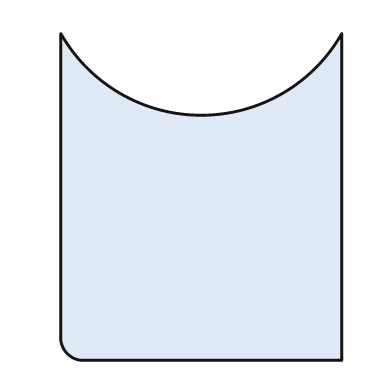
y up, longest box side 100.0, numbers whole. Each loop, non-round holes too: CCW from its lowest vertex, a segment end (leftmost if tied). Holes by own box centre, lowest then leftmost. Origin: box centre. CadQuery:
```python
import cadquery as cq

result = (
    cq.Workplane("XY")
    .moveTo(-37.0, -50.0)
    .lineTo(43.0, -50.0)
    .lineTo(43.0, 50.0)
    .threePointArc((0.0, 25.0), (-43.0, 50.0))
    .lineTo(-43.0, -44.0)
    .threePointArc((-41.0, -48.0), (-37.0, -50.0))
    .close()
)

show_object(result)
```